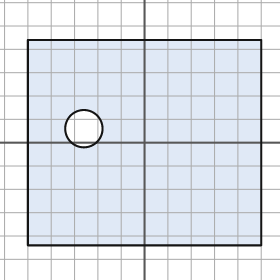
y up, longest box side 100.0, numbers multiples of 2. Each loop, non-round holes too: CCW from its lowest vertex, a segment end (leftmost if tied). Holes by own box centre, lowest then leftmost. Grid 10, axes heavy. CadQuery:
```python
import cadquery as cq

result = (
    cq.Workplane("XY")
    .moveTo(-50.0, -44.0)
    .lineTo(50.0, -44.0)
    .lineTo(50.0, 44.0)
    .lineTo(-50.0, 44.0)
    .close()
    .moveTo(-26.0, 6.0)
    .circle(8.0)
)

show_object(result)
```